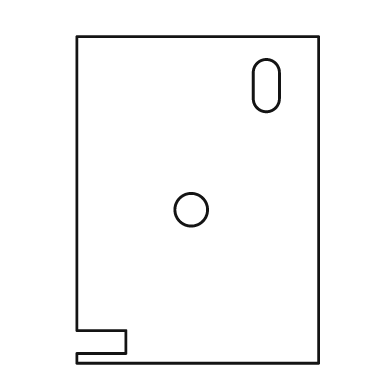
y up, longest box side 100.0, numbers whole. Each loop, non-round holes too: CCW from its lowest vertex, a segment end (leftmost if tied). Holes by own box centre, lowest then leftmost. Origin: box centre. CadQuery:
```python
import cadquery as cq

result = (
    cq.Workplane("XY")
    .moveTo(-37.0, -50.0)
    .lineTo(37.0, -50.0)
    .lineTo(37.0, 50.0)
    .lineTo(-37.0, 50.0)
    .lineTo(-37.0, -40.0)
    .lineTo(-22.0, -40.0)
    .lineTo(-22.0, -47.0)
    .lineTo(-37.0, -47.0)
    .close()
    .moveTo(-2.0, -3.0)
    .circle(5.0)
    .moveTo(17.0, 31.0)
    .threePointArc((21.0, 27.0), (25.0, 31.0))
    .lineTo(25.0, 39.0)
    .threePointArc((21.0, 43.0), (17.0, 39.0))
    .close()
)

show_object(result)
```